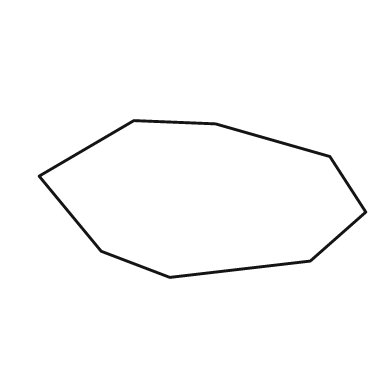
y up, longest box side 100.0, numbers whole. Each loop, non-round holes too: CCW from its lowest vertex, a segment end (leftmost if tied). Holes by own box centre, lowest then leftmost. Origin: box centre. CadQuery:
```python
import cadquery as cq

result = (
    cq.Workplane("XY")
    .moveTo(-10.0, -24.0)
    .lineTo(33.0, -19.0)
    .lineTo(50.0, -4.0)
    .lineTo(39.0, 13.0)
    .lineTo(4.0, 23.0)
    .lineTo(-21.0, 24.0)
    .lineTo(-50.0, 7.0)
    .lineTo(-31.0, -16.0)
    .close()
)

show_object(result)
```